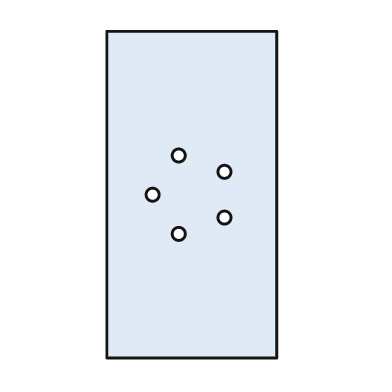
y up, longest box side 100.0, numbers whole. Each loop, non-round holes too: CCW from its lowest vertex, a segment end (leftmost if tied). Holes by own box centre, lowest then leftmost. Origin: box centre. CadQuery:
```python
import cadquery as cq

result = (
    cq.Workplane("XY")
    .moveTo(-26.0, -50.0)
    .lineTo(26.0, -50.0)
    .lineTo(26.0, 50.0)
    .lineTo(-26.0, 50.0)
    .close()
    .moveTo(-4.0, -12.0)
    .circle(2.0)
    .moveTo(10.0, -7.0)
    .circle(2.0)
    .moveTo(-12.0, 0.0)
    .circle(2.0)
    .moveTo(10.0, 7.0)
    .circle(2.0)
    .moveTo(-4.0, 12.0)
    .circle(2.0)
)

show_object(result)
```